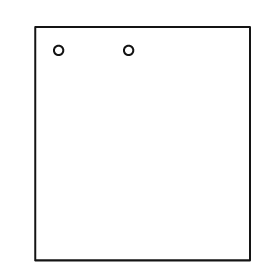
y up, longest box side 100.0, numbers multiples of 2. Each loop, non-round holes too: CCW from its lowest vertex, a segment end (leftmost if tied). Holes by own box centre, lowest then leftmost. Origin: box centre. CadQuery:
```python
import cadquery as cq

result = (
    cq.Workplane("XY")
    .moveTo(-46.0, -50.0)
    .lineTo(46.0, -50.0)
    .lineTo(46.0, 50.0)
    .lineTo(-46.0, 50.0)
    .close()
    .moveTo(-36.0, 40.0)
    .circle(2.0)
    .moveTo(-6.0, 40.0)
    .circle(2.0)
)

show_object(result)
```